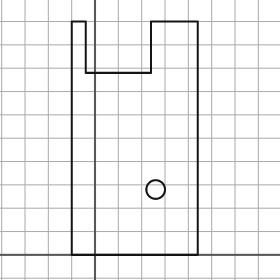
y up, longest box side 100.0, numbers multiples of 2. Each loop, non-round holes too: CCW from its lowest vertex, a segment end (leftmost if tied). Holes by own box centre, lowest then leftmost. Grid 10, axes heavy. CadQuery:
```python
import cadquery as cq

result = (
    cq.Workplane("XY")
    .moveTo(-10.0, 0.0)
    .lineTo(44.0, 0.0)
    .lineTo(44.0, 100.0)
    .lineTo(24.0, 100.0)
    .lineTo(24.0, 78.0)
    .lineTo(-4.0, 78.0)
    .lineTo(-4.0, 100.0)
    .lineTo(-10.0, 100.0)
    .close()
    .moveTo(26.0, 28.0)
    .circle(4.0)
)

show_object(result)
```